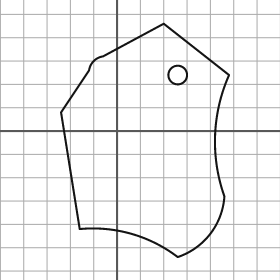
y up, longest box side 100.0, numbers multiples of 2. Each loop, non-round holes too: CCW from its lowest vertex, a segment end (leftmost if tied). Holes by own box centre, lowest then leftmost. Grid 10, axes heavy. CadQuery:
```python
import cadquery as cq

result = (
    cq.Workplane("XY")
    .moveTo(26.0, -54.0)
    .threePointArc((40.0, -44.0), (46.0, -28.0))
    .threePointArc((42.0, -2.0), (48.0, 24.0))
    .lineTo(20.0, 46.0)
    .lineTo(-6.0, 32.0)
    .threePointArc((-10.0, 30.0), (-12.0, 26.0))
    .lineTo(-24.0, 8.0)
    .lineTo(-16.0, -42.0)
    .threePointArc((6.0, -44.0), (26.0, -54.0))
    .close()
    .moveTo(26.0, 24.0)
    .circle(4.0)
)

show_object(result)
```